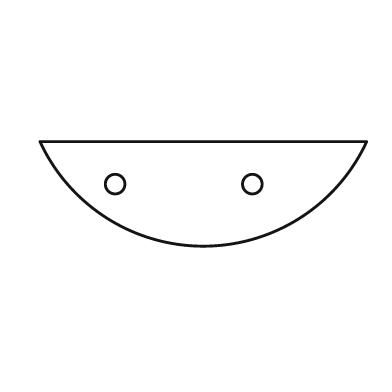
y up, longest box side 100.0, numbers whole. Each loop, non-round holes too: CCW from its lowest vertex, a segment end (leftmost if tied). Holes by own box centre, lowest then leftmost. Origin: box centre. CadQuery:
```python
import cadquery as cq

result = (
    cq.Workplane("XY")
    .moveTo(-50.0, 16.0)
    .threePointArc((0.0, -16.0), (50.0, 16.0))
    .close()
    .moveTo(-27.0, 3.0)
    .circle(3.0)
    .moveTo(15.0, 3.0)
    .circle(3.0)
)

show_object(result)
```